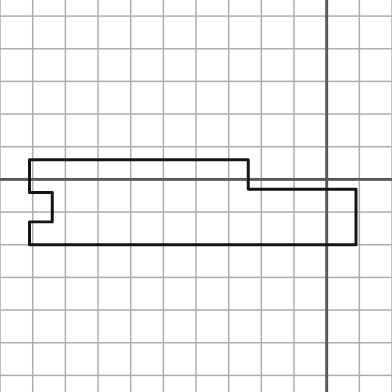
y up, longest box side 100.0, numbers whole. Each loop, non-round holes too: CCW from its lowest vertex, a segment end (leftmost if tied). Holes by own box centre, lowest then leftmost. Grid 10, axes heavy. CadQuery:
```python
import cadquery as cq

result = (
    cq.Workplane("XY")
    .moveTo(-91.0, -20.0)
    .lineTo(9.0, -20.0)
    .lineTo(9.0, -3.0)
    .lineTo(-24.0, -3.0)
    .lineTo(-24.0, 6.0)
    .lineTo(-91.0, 6.0)
    .lineTo(-91.0, -4.0)
    .lineTo(-84.0, -4.0)
    .lineTo(-84.0, -13.0)
    .lineTo(-91.0, -13.0)
    .close()
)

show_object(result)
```